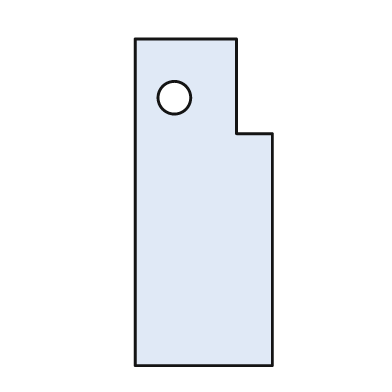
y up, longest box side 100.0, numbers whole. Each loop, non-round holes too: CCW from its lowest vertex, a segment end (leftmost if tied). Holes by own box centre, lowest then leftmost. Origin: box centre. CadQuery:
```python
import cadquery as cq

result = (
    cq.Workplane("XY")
    .moveTo(-21.0, -50.0)
    .lineTo(21.0, -50.0)
    .lineTo(21.0, 21.0)
    .lineTo(10.0, 21.0)
    .lineTo(10.0, 50.0)
    .lineTo(-21.0, 50.0)
    .close()
    .moveTo(-9.0, 32.0)
    .circle(5.0)
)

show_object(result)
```